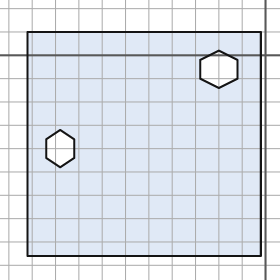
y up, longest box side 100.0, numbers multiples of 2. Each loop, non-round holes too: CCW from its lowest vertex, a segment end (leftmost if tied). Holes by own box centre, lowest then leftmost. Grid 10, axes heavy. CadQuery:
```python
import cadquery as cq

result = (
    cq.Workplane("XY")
    .moveTo(-102.0, -86.0)
    .lineTo(-2.0, -86.0)
    .lineTo(-2.0, 10.0)
    .lineTo(-102.0, 10.0)
    .close()
    .moveTo(-88.0, -48.0)
    .lineTo(-82.0, -44.0)
    .lineTo(-82.0, -36.0)
    .lineTo(-88.0, -32.0)
    .lineTo(-94.0, -36.0)
    .lineTo(-94.0, -44.0)
    .close()
    .moveTo(-20.0, -14.0)
    .lineTo(-12.0, -10.0)
    .lineTo(-12.0, -2.0)
    .lineTo(-20.0, 2.0)
    .lineTo(-28.0, -2.0)
    .lineTo(-28.0, -10.0)
    .close()
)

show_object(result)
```